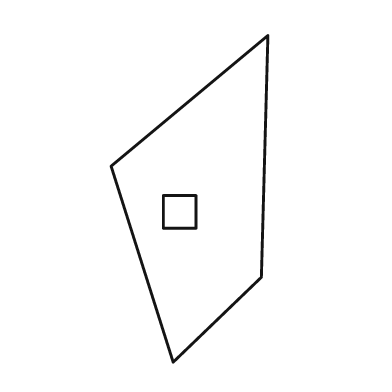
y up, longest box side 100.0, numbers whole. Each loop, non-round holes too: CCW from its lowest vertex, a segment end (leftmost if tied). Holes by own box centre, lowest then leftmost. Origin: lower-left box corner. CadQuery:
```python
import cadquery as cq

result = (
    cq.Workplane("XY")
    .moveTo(19.0, 0.0)
    .lineTo(46.0, 26.0)
    .lineTo(48.0, 100.0)
    .lineTo(0.0, 60.0)
    .close()
    .moveTo(16.0, 41.0)
    .lineTo(26.0, 41.0)
    .lineTo(26.0, 51.0)
    .lineTo(16.0, 51.0)
    .close()
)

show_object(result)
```